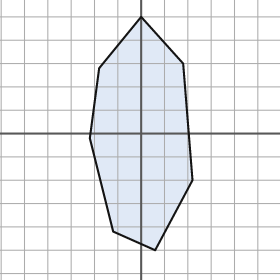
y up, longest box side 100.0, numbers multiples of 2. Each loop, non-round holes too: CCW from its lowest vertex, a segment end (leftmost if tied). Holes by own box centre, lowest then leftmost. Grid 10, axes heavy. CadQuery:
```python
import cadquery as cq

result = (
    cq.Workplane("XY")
    .moveTo(6.0, -50.0)
    .lineTo(22.0, -20.0)
    .lineTo(18.0, 30.0)
    .lineTo(0.0, 50.0)
    .lineTo(-18.0, 28.0)
    .lineTo(-22.0, -2.0)
    .lineTo(-12.0, -42.0)
    .close()
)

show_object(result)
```